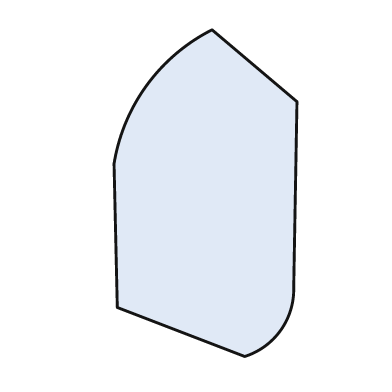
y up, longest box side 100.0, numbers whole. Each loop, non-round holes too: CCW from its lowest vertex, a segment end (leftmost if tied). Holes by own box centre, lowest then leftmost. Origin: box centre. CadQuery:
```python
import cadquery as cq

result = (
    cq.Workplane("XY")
    .moveTo(12.0, -50.0)
    .threePointArc((23.0, -42.0), (27.0, -29.0))
    .lineTo(28.0, 28.0)
    .lineTo(2.0, 50.0)
    .threePointArc((-18.0, 33.0), (-28.0, 9.0))
    .lineTo(-27.0, -35.0)
    .close()
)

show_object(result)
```